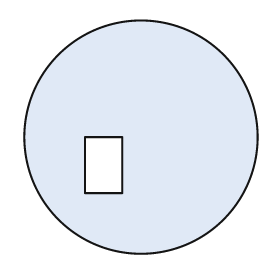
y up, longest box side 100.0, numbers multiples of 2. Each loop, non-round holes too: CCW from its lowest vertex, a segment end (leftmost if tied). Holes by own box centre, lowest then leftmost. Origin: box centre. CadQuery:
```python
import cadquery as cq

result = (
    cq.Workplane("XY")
    .moveTo(0.0, 0.0)
    .circle(50.0)
    .moveTo(-24.0, -24.0)
    .lineTo(-8.0, -24.0)
    .lineTo(-8.0, 0.0)
    .lineTo(-24.0, 0.0)
    .close()
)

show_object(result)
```